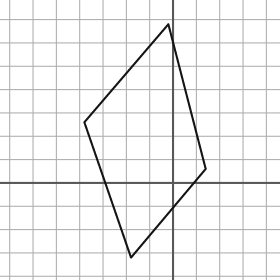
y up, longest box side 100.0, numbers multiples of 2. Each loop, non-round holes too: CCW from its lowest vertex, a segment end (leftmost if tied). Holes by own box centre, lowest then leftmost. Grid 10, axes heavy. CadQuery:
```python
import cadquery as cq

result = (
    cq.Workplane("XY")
    .moveTo(-18.0, -32.0)
    .lineTo(14.0, 6.0)
    .lineTo(-2.0, 68.0)
    .lineTo(-38.0, 26.0)
    .close()
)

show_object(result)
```